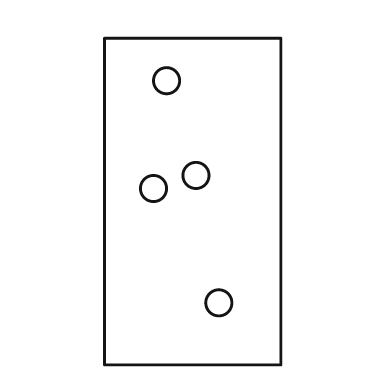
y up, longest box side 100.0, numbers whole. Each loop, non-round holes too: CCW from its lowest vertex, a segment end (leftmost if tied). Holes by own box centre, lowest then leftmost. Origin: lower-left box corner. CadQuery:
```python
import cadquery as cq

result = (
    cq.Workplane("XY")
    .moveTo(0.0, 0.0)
    .lineTo(54.0, 0.0)
    .lineTo(54.0, 100.0)
    .lineTo(0.0, 100.0)
    .close()
    .moveTo(35.0, 19.0)
    .circle(4.0)
    .moveTo(15.0, 54.0)
    .circle(4.0)
    .moveTo(28.0, 58.0)
    .circle(4.0)
    .moveTo(19.0, 87.0)
    .circle(4.0)
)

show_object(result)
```